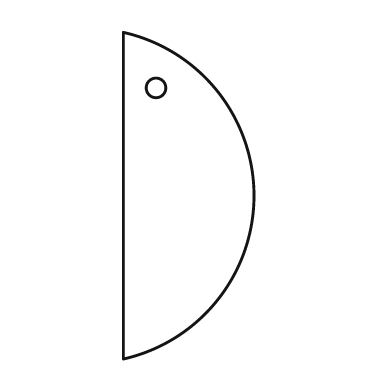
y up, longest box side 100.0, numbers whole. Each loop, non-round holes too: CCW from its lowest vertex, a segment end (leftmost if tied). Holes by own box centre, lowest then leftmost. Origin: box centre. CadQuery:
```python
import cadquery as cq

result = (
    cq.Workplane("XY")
    .moveTo(-20.0, -50.0)
    .threePointArc((20.0, 0.0), (-20.0, 50.0))
    .close()
    .moveTo(-10.0, 33.0)
    .circle(3.0)
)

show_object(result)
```